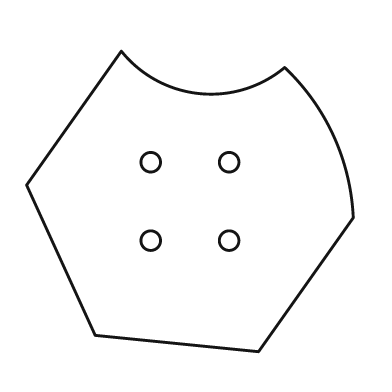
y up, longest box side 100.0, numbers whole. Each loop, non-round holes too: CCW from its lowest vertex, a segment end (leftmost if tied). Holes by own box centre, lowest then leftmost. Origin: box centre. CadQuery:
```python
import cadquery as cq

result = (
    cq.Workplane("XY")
    .moveTo(21.0, -46.0)
    .lineTo(50.0, -5.0)
    .threePointArc((44.0, 20.0), (29.0, 41.0))
    .threePointArc((3.0, 33.0), (-21.0, 46.0))
    .lineTo(-50.0, 5.0)
    .lineTo(-29.0, -41.0)
    .close()
    .moveTo(-12.0, -12.0)
    .circle(3.0)
    .moveTo(12.0, -12.0)
    .circle(3.0)
    .moveTo(-12.0, 12.0)
    .circle(3.0)
    .moveTo(12.0, 12.0)
    .circle(3.0)
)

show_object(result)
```